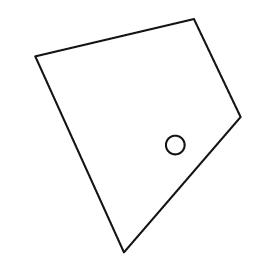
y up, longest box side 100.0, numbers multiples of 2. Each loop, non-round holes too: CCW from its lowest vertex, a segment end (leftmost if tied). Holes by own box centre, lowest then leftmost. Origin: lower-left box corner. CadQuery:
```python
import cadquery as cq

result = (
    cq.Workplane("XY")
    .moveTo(38.0, 0.0)
    .lineTo(88.0, 58.0)
    .lineTo(68.0, 100.0)
    .lineTo(0.0, 84.0)
    .close()
    .moveTo(60.0, 46.0)
    .circle(4.0)
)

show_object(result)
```